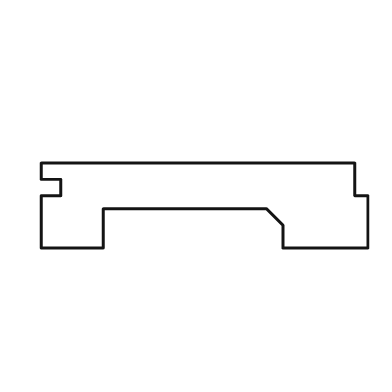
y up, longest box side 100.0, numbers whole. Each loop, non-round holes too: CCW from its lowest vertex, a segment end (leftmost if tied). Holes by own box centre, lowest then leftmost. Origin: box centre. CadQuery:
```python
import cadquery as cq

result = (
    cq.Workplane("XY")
    .moveTo(-50.0, -13.0)
    .lineTo(-31.0, -13.0)
    .lineTo(-31.0, -1.0)
    .lineTo(19.0, -1.0)
    .lineTo(24.0, -6.0)
    .lineTo(24.0, -13.0)
    .lineTo(50.0, -13.0)
    .lineTo(50.0, 3.0)
    .lineTo(46.0, 3.0)
    .lineTo(46.0, 13.0)
    .lineTo(-50.0, 13.0)
    .lineTo(-50.0, 8.0)
    .lineTo(-44.0, 8.0)
    .lineTo(-44.0, 3.0)
    .lineTo(-50.0, 3.0)
    .close()
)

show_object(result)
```